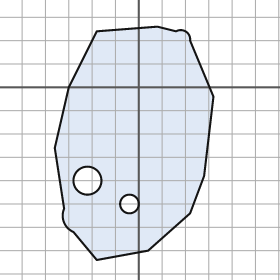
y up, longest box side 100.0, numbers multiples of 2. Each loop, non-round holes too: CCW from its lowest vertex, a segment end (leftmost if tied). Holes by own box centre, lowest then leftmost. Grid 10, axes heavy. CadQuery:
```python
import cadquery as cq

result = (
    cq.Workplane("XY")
    .moveTo(-18.0, -74.0)
    .lineTo(4.0, -70.0)
    .lineTo(22.0, -54.0)
    .lineTo(28.0, -38.0)
    .lineTo(32.0, -4.0)
    .lineTo(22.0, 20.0)
    .threePointArc((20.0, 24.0), (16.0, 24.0))
    .lineTo(8.0, 26.0)
    .lineTo(-18.0, 24.0)
    .lineTo(-30.0, 0.0)
    .lineTo(-36.0, -26.0)
    .lineTo(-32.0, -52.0)
    .threePointArc((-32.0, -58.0), (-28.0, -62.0))
    .close()
    .moveTo(-4.0, -50.0)
    .circle(4.0)
    .moveTo(-22.0, -40.0)
    .circle(6.0)
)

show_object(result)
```